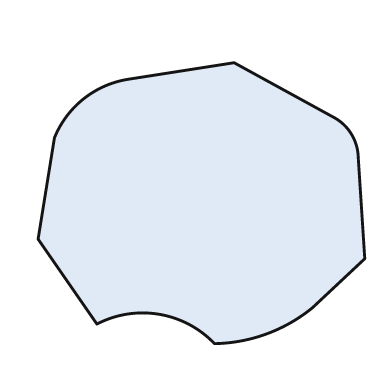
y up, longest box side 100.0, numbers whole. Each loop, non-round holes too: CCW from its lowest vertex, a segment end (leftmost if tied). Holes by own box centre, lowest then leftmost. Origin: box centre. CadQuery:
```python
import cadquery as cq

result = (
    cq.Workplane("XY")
    .moveTo(4.0, -43.0)
    .threePointArc((20.0, -40.0), (34.0, -32.0))
    .lineTo(50.0, -17.0)
    .lineTo(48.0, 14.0)
    .threePointArc((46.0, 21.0), (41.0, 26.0))
    .lineTo(10.0, 43.0)
    .lineTo(-22.0, 38.0)
    .threePointArc((-36.0, 32.0), (-45.0, 20.0))
    .lineTo(-50.0, -11.0)
    .lineTo(-32.0, -37.0)
    .threePointArc((-13.0, -34.0), (4.0, -43.0))
    .close()
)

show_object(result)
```